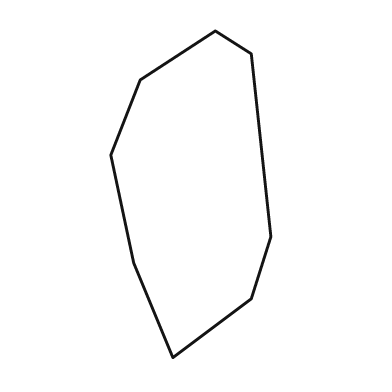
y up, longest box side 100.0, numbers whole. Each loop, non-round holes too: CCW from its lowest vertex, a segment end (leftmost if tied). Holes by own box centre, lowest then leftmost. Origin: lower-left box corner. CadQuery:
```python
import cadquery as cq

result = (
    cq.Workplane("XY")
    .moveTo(19.0, 0.0)
    .lineTo(43.0, 18.0)
    .lineTo(49.0, 37.0)
    .lineTo(43.0, 93.0)
    .lineTo(32.0, 100.0)
    .lineTo(9.0, 85.0)
    .lineTo(0.0, 62.0)
    .lineTo(7.0, 29.0)
    .close()
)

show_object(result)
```